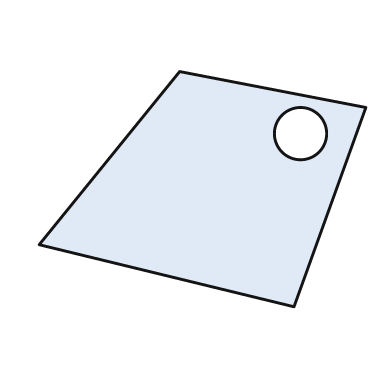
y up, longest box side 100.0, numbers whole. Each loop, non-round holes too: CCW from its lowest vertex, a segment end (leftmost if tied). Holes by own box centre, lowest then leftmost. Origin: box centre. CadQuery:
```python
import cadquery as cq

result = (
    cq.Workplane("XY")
    .moveTo(28.0, -36.0)
    .lineTo(50.0, 25.0)
    .lineTo(-7.0, 36.0)
    .lineTo(-50.0, -17.0)
    .close()
    .moveTo(30.0, 17.0)
    .circle(8.0)
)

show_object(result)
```